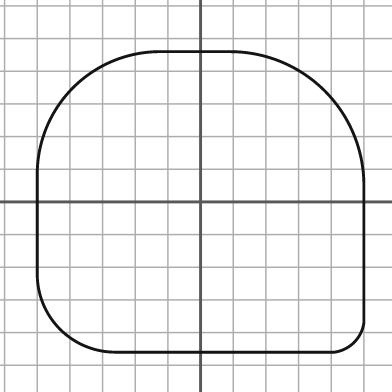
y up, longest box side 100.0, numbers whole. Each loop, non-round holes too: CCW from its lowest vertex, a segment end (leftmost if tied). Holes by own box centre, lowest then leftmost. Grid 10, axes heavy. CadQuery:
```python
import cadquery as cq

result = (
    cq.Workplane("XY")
    .moveTo(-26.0, -46.0)
    .lineTo(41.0, -46.0)
    .threePointArc((47.0, -43.0), (50.0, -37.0))
    .lineTo(50.0, 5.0)
    .threePointArc((38.0, 34.0), (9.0, 46.0))
    .lineTo(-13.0, 46.0)
    .threePointArc((-39.0, 35.0), (-50.0, 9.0))
    .lineTo(-50.0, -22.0)
    .threePointArc((-43.0, -39.0), (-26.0, -46.0))
    .close()
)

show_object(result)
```